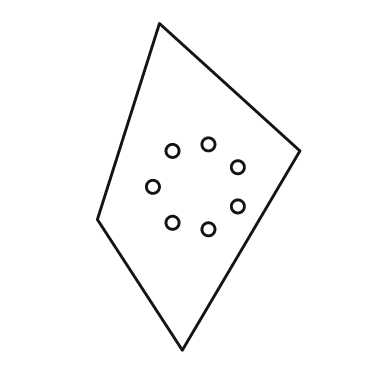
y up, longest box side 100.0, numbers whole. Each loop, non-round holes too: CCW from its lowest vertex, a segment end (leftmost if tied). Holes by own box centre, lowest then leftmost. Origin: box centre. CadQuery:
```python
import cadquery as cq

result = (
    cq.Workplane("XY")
    .moveTo(-5.0, -50.0)
    .lineTo(31.0, 11.0)
    .lineTo(-12.0, 50.0)
    .lineTo(-31.0, -10.0)
    .close()
    .moveTo(3.0, -13.0)
    .circle(2.0)
    .moveTo(-8.0, -11.0)
    .circle(2.0)
    .moveTo(12.0, -6.0)
    .circle(2.0)
    .moveTo(-14.0, 0.0)
    .circle(2.0)
    .moveTo(12.0, 6.0)
    .circle(2.0)
    .moveTo(-8.0, 11.0)
    .circle(2.0)
    .moveTo(3.0, 13.0)
    .circle(2.0)
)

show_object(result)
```